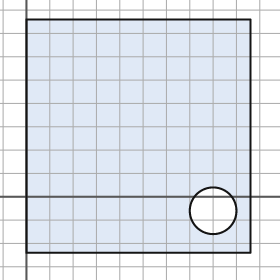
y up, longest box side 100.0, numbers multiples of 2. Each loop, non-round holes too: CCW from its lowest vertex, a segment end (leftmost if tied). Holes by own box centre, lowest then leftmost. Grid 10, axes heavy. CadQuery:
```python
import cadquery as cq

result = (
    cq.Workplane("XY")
    .moveTo(0.0, -24.0)
    .lineTo(96.0, -24.0)
    .lineTo(96.0, 76.0)
    .lineTo(0.0, 76.0)
    .close()
    .moveTo(80.0, -6.0)
    .circle(10.0)
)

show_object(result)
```